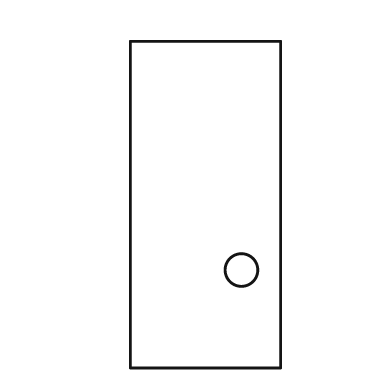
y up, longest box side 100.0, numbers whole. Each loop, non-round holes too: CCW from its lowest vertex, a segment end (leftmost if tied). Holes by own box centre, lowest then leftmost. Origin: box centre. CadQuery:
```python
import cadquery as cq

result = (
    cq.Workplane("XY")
    .moveTo(-23.0, -50.0)
    .lineTo(23.0, -50.0)
    .lineTo(23.0, 50.0)
    .lineTo(-23.0, 50.0)
    .close()
    .moveTo(11.0, -20.0)
    .circle(5.0)
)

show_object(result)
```